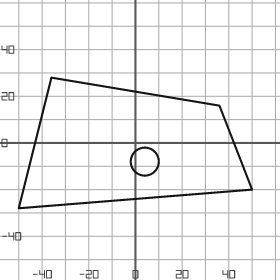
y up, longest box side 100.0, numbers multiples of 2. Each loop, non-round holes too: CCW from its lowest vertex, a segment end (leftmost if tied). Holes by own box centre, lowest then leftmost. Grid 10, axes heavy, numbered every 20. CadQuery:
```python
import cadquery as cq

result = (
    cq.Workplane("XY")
    .moveTo(-50.0, -28.0)
    .lineTo(50.0, -20.0)
    .lineTo(36.0, 16.0)
    .lineTo(-36.0, 28.0)
    .close()
    .moveTo(4.0, -8.0)
    .circle(6.0)
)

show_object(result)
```